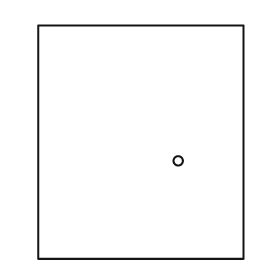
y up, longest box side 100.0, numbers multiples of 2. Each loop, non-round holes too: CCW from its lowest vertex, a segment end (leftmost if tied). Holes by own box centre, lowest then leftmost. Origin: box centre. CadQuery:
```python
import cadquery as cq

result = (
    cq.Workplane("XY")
    .moveTo(-44.0, -50.0)
    .lineTo(44.0, -50.0)
    .lineTo(44.0, 50.0)
    .lineTo(-44.0, 50.0)
    .close()
    .moveTo(16.0, -8.0)
    .circle(2.0)
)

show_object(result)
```